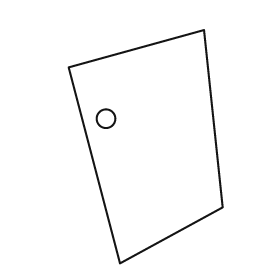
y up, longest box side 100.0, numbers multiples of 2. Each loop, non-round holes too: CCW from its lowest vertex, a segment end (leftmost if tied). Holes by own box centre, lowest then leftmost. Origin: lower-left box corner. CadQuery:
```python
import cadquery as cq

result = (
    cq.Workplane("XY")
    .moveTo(22.0, 0.0)
    .lineTo(66.0, 24.0)
    .lineTo(58.0, 100.0)
    .lineTo(0.0, 84.0)
    .close()
    .moveTo(16.0, 62.0)
    .circle(4.0)
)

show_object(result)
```